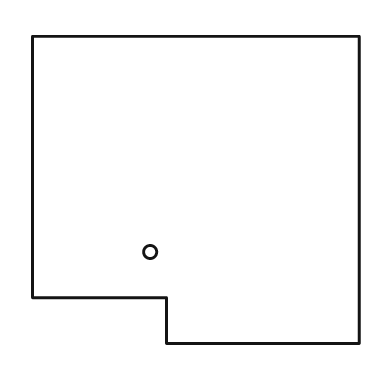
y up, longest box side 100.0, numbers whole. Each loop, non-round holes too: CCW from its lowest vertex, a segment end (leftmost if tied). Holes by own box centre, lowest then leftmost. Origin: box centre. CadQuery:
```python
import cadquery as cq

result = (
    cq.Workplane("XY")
    .moveTo(-9.0, -47.0)
    .lineTo(50.0, -47.0)
    .lineTo(50.0, 47.0)
    .lineTo(-50.0, 47.0)
    .lineTo(-50.0, -33.0)
    .lineTo(-9.0, -33.0)
    .close()
    .moveTo(-14.0, -19.0)
    .circle(2.0)
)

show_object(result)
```